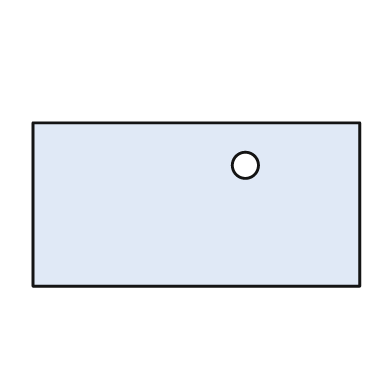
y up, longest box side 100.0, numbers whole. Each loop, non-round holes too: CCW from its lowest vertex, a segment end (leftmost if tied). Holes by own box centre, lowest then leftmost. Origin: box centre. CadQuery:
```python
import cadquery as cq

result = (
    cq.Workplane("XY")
    .moveTo(-50.0, -25.0)
    .lineTo(50.0, -25.0)
    .lineTo(50.0, 25.0)
    .lineTo(-50.0, 25.0)
    .close()
    .moveTo(15.0, 12.0)
    .circle(4.0)
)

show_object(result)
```